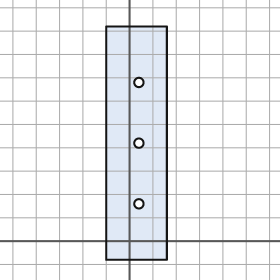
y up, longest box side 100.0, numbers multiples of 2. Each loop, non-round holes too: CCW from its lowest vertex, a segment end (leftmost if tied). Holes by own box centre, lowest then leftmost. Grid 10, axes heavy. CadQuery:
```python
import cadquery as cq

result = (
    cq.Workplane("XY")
    .moveTo(-10.0, -8.0)
    .lineTo(16.0, -8.0)
    .lineTo(16.0, 92.0)
    .lineTo(-10.0, 92.0)
    .close()
    .moveTo(4.0, 16.0)
    .circle(2.0)
    .moveTo(4.0, 42.0)
    .circle(2.0)
    .moveTo(4.0, 68.0)
    .circle(2.0)
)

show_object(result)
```